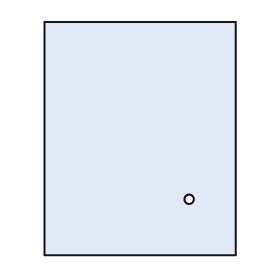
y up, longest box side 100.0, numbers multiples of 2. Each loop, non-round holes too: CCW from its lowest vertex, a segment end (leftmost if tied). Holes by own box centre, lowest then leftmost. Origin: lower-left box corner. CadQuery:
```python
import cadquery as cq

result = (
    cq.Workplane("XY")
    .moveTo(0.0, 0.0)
    .lineTo(82.0, 0.0)
    .lineTo(82.0, 100.0)
    .lineTo(0.0, 100.0)
    .close()
    .moveTo(62.0, 24.0)
    .circle(2.0)
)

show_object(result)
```